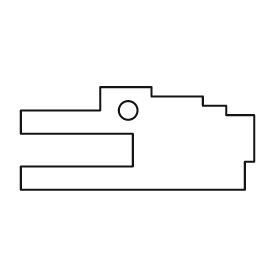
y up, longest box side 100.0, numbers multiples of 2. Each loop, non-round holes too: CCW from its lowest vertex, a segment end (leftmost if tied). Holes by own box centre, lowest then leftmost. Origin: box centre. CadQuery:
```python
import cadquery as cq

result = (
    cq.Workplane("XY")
    .moveTo(-50.0, -22.0)
    .lineTo(46.0, -22.0)
    .lineTo(46.0, -10.0)
    .lineTo(50.0, -10.0)
    .lineTo(50.0, 10.0)
    .lineTo(38.0, 10.0)
    .lineTo(38.0, 14.0)
    .lineTo(28.0, 14.0)
    .lineTo(28.0, 18.0)
    .lineTo(6.0, 18.0)
    .lineTo(6.0, 22.0)
    .lineTo(-16.0, 22.0)
    .lineTo(-16.0, 12.0)
    .lineTo(-50.0, 12.0)
    .lineTo(-50.0, 2.0)
    .lineTo(-2.0, 2.0)
    .lineTo(-2.0, -12.0)
    .lineTo(-50.0, -12.0)
    .close()
    .moveTo(-4.0, 12.0)
    .circle(4.0)
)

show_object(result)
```